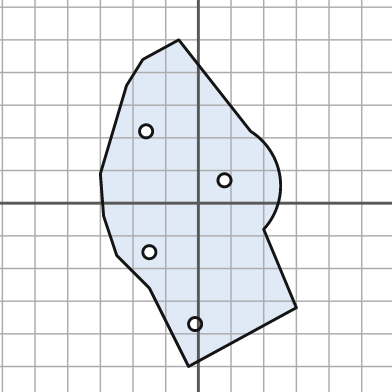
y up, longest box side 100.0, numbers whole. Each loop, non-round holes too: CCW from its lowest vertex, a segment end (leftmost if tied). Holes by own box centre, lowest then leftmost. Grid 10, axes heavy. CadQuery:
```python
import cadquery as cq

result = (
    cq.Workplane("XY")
    .moveTo(-3.0, -50.0)
    .lineTo(30.0, -32.0)
    .lineTo(20.0, -8.0)
    .threePointArc((25.0, 8.0), (16.0, 22.0))
    .lineTo(-6.0, 50.0)
    .lineTo(-17.0, 44.0)
    .lineTo(-22.0, 36.0)
    .lineTo(-30.0, 9.0)
    .lineTo(-29.0, -4.0)
    .lineTo(-25.0, -16.0)
    .lineTo(-15.0, -26.0)
    .close()
    .moveTo(-1.0, -37.0)
    .circle(2.0)
    .moveTo(-15.0, -15.0)
    .circle(2.0)
    .moveTo(8.0, 7.0)
    .circle(2.0)
    .moveTo(-16.0, 22.0)
    .circle(2.0)
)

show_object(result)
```